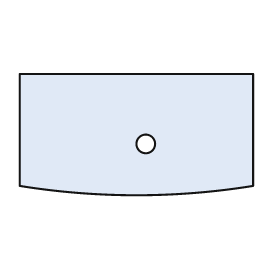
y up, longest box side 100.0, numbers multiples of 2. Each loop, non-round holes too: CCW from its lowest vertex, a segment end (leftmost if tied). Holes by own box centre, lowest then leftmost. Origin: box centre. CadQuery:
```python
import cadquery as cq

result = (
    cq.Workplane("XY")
    .moveTo(-50.0, -22.0)
    .threePointArc((0.0, -26.0), (50.0, -22.0))
    .lineTo(50.0, 26.0)
    .lineTo(-50.0, 26.0)
    .close()
    .moveTo(4.0, -4.0)
    .circle(4.0)
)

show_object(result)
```